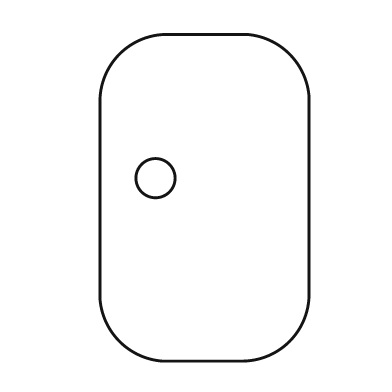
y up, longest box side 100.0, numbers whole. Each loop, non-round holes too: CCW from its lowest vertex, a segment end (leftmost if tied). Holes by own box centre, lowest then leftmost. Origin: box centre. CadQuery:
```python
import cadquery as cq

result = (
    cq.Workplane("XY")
    .moveTo(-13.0, -50.0)
    .lineTo(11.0, -50.0)
    .threePointArc((26.0, -44.0), (32.0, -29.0))
    .lineTo(32.0, 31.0)
    .threePointArc((26.0, 44.0), (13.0, 50.0))
    .lineTo(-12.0, 50.0)
    .threePointArc((-26.0, 44.0), (-32.0, 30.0))
    .lineTo(-32.0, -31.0)
    .threePointArc((-26.0, -44.0), (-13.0, -50.0))
    .close()
    .moveTo(-15.0, 6.0)
    .circle(6.0)
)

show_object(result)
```